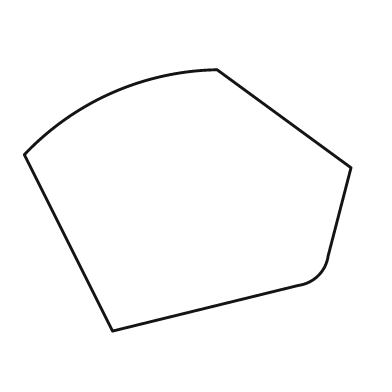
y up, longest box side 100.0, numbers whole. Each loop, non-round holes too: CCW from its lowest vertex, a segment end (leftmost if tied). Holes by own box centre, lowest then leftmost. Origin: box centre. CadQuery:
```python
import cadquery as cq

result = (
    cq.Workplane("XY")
    .moveTo(-23.0, -40.0)
    .lineTo(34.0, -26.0)
    .threePointArc((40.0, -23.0), (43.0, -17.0))
    .lineTo(50.0, 10.0)
    .lineTo(9.0, 40.0)
    .threePointArc((-23.0, 33.0), (-50.0, 14.0))
    .close()
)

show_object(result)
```